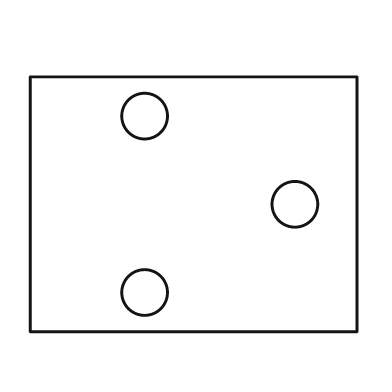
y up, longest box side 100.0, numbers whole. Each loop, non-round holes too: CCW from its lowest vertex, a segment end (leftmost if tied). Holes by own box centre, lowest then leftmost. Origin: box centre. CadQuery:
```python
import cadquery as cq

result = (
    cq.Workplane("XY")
    .moveTo(-50.0, -39.0)
    .lineTo(50.0, -39.0)
    .lineTo(50.0, 39.0)
    .lineTo(-50.0, 39.0)
    .close()
    .moveTo(-15.0, -27.0)
    .circle(7.0)
    .moveTo(31.0, 0.0)
    .circle(7.0)
    .moveTo(-15.0, 27.0)
    .circle(7.0)
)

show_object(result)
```